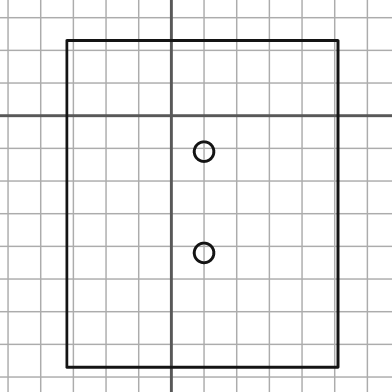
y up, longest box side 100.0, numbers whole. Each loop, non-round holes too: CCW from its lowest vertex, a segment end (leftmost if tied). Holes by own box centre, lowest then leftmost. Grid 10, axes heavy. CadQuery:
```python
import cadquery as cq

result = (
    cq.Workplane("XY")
    .moveTo(-32.0, -77.0)
    .lineTo(51.0, -77.0)
    .lineTo(51.0, 23.0)
    .lineTo(-32.0, 23.0)
    .close()
    .moveTo(10.0, -42.0)
    .circle(3.0)
    .moveTo(10.0, -11.0)
    .circle(3.0)
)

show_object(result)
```